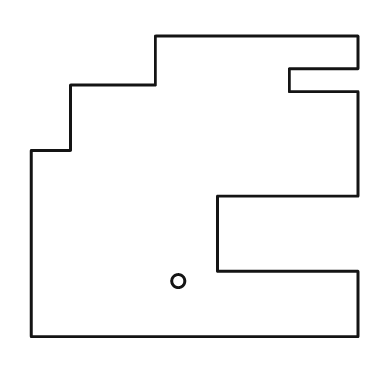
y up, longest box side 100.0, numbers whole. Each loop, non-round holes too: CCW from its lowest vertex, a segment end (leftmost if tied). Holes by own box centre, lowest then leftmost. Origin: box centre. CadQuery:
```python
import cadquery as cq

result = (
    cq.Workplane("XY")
    .moveTo(-50.0, -46.0)
    .lineTo(50.0, -46.0)
    .lineTo(50.0, -26.0)
    .lineTo(7.0, -26.0)
    .lineTo(7.0, -3.0)
    .lineTo(50.0, -3.0)
    .lineTo(50.0, 29.0)
    .lineTo(29.0, 29.0)
    .lineTo(29.0, 36.0)
    .lineTo(50.0, 36.0)
    .lineTo(50.0, 46.0)
    .lineTo(-12.0, 46.0)
    .lineTo(-12.0, 31.0)
    .lineTo(-38.0, 31.0)
    .lineTo(-38.0, 11.0)
    .lineTo(-50.0, 11.0)
    .close()
    .moveTo(-5.0, -29.0)
    .circle(2.0)
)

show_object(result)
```